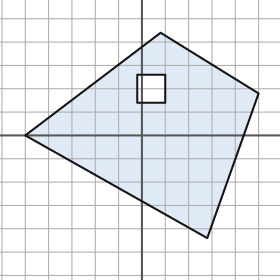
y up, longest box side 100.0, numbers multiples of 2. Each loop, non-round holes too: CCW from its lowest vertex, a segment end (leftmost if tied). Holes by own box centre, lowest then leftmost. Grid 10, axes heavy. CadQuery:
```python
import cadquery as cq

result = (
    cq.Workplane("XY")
    .moveTo(28.0, -44.0)
    .lineTo(50.0, 18.0)
    .lineTo(8.0, 44.0)
    .lineTo(-50.0, 0.0)
    .close()
    .moveTo(-2.0, 14.0)
    .lineTo(10.0, 14.0)
    .lineTo(10.0, 26.0)
    .lineTo(-2.0, 26.0)
    .close()
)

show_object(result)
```